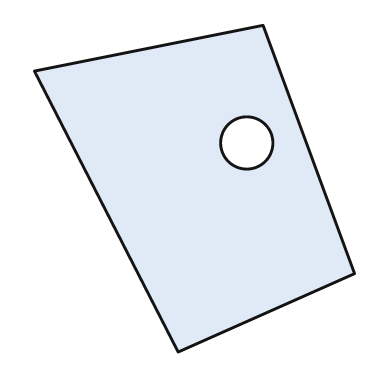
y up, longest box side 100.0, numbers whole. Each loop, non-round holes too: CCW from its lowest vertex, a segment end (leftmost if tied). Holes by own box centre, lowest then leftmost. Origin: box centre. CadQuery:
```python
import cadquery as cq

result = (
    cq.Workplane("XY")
    .moveTo(-5.0, -50.0)
    .lineTo(49.0, -26.0)
    .lineTo(21.0, 50.0)
    .lineTo(-49.0, 36.0)
    .close()
    .moveTo(16.0, 14.0)
    .circle(8.0)
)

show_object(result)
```